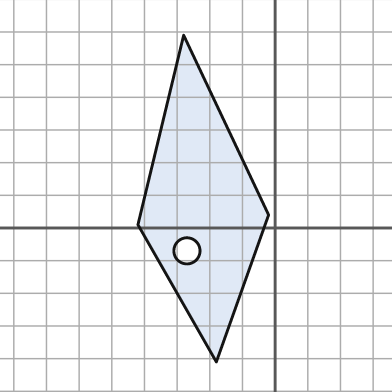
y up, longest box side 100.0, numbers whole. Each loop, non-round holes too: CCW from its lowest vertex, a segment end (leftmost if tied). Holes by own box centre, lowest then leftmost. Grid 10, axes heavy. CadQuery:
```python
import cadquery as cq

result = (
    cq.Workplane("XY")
    .moveTo(-18.0, -41.0)
    .lineTo(-2.0, 4.0)
    .lineTo(-28.0, 59.0)
    .lineTo(-42.0, 1.0)
    .close()
    .moveTo(-27.0, -7.0)
    .circle(4.0)
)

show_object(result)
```